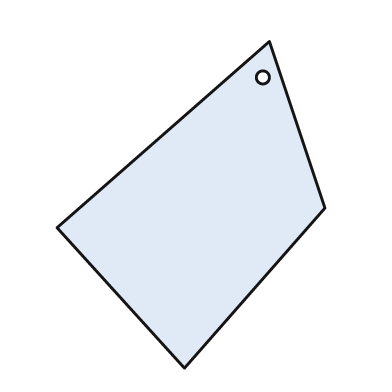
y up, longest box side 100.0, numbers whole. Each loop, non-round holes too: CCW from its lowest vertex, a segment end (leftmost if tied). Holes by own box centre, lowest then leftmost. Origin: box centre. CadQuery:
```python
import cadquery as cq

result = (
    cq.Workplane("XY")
    .moveTo(-2.0, -50.0)
    .lineTo(41.0, -1.0)
    .lineTo(24.0, 50.0)
    .lineTo(-41.0, -7.0)
    .close()
    .moveTo(22.0, 39.0)
    .circle(2.0)
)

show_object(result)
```